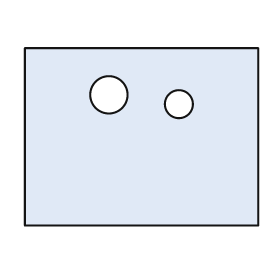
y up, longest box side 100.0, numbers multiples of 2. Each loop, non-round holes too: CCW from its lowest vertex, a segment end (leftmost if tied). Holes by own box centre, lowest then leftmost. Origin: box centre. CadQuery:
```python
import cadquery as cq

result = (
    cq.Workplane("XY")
    .moveTo(-50.0, -38.0)
    .lineTo(50.0, -38.0)
    .lineTo(50.0, 38.0)
    .lineTo(-50.0, 38.0)
    .close()
    .moveTo(16.0, 14.0)
    .circle(6.0)
    .moveTo(-14.0, 18.0)
    .circle(8.0)
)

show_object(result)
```